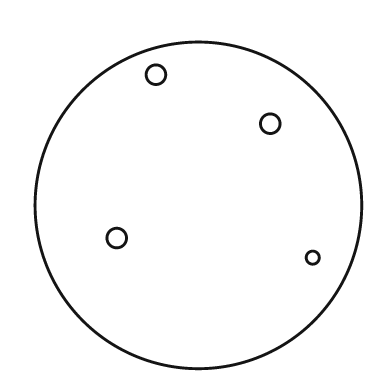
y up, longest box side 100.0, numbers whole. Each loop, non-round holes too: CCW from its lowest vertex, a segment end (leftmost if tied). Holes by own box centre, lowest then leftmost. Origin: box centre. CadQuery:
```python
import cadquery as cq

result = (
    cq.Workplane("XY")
    .moveTo(0.0, 0.0)
    .circle(50.0)
    .moveTo(35.0, -16.0)
    .circle(2.0)
    .moveTo(-25.0, -10.0)
    .circle(3.0)
    .moveTo(22.0, 25.0)
    .circle(3.0)
    .moveTo(-13.0, 40.0)
    .circle(3.0)
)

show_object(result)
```